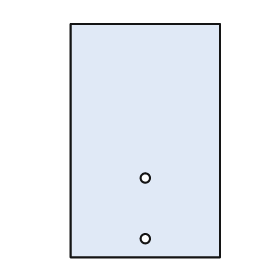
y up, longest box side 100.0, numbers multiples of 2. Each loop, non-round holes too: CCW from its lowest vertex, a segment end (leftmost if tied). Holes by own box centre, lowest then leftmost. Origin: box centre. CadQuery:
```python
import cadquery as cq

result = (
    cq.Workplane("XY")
    .moveTo(-32.0, -50.0)
    .lineTo(32.0, -50.0)
    .lineTo(32.0, 50.0)
    .lineTo(-32.0, 50.0)
    .close()
    .moveTo(0.0, -42.0)
    .circle(2.0)
    .moveTo(0.0, -16.0)
    .circle(2.0)
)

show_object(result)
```